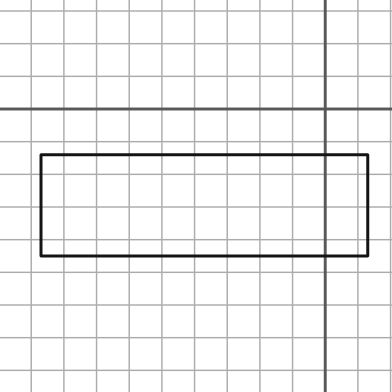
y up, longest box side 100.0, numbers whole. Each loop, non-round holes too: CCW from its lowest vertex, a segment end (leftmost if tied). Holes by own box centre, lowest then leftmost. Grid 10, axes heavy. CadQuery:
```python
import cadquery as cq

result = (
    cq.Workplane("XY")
    .moveTo(-87.0, -45.0)
    .lineTo(13.0, -45.0)
    .lineTo(13.0, -14.0)
    .lineTo(-87.0, -14.0)
    .close()
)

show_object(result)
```